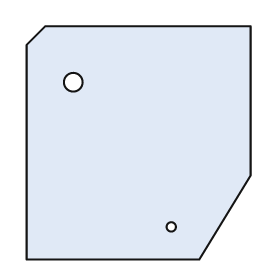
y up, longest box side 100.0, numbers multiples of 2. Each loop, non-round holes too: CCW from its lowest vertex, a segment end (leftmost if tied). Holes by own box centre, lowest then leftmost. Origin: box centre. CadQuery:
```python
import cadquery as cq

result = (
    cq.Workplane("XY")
    .moveTo(-48.0, -50.0)
    .lineTo(26.0, -50.0)
    .lineTo(48.0, -14.0)
    .lineTo(48.0, 50.0)
    .lineTo(-40.0, 50.0)
    .lineTo(-48.0, 42.0)
    .close()
    .moveTo(14.0, -36.0)
    .circle(2.0)
    .moveTo(-28.0, 26.0)
    .circle(4.0)
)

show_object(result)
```